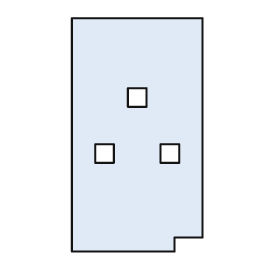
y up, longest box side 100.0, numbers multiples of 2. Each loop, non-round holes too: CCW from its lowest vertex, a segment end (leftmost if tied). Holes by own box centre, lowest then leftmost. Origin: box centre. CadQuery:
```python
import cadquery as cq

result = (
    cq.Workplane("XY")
    .moveTo(-28.0, -50.0)
    .lineTo(16.0, -50.0)
    .lineTo(16.0, -44.0)
    .lineTo(28.0, -44.0)
    .lineTo(28.0, 50.0)
    .lineTo(-28.0, 50.0)
    .close()
    .moveTo(-18.0, -12.0)
    .lineTo(-10.0, -12.0)
    .lineTo(-10.0, -4.0)
    .lineTo(-18.0, -4.0)
    .close()
    .moveTo(10.0, -12.0)
    .lineTo(18.0, -12.0)
    .lineTo(18.0, -4.0)
    .lineTo(10.0, -4.0)
    .close()
    .moveTo(-4.0, 12.0)
    .lineTo(4.0, 12.0)
    .lineTo(4.0, 20.0)
    .lineTo(-4.0, 20.0)
    .close()
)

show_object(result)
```